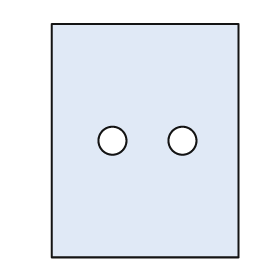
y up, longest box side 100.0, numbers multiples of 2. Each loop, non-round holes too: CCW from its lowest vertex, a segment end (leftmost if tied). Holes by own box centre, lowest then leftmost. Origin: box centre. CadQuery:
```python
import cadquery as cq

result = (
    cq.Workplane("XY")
    .moveTo(-40.0, -50.0)
    .lineTo(40.0, -50.0)
    .lineTo(40.0, 50.0)
    .lineTo(-40.0, 50.0)
    .close()
    .moveTo(-14.0, 0.0)
    .circle(6.0)
    .moveTo(16.0, 0.0)
    .circle(6.0)
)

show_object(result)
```